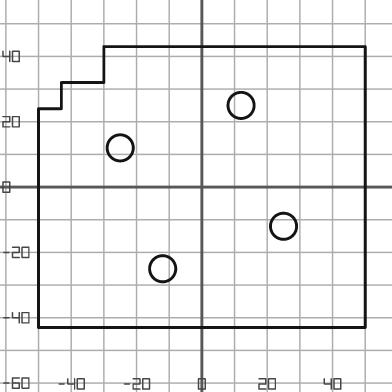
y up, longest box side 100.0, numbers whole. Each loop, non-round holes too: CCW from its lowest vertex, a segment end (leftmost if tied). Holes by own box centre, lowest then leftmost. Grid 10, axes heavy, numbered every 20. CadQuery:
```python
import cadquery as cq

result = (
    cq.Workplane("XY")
    .moveTo(-50.0, -43.0)
    .lineTo(50.0, -43.0)
    .lineTo(50.0, 43.0)
    .lineTo(-30.0, 43.0)
    .lineTo(-30.0, 32.0)
    .lineTo(-43.0, 32.0)
    .lineTo(-43.0, 24.0)
    .lineTo(-50.0, 24.0)
    .close()
    .moveTo(-12.0, -25.0)
    .circle(4.0)
    .moveTo(25.0, -12.0)
    .circle(4.0)
    .moveTo(-25.0, 12.0)
    .circle(4.0)
    .moveTo(12.0, 25.0)
    .circle(4.0)
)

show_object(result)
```